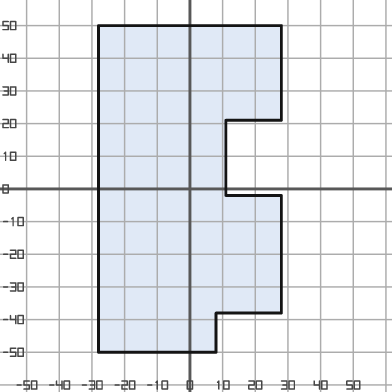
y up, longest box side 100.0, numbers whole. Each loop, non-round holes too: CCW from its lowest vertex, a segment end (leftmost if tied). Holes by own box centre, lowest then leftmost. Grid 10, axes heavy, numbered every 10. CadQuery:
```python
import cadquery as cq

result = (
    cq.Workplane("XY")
    .moveTo(-28.0, -50.0)
    .lineTo(8.0, -50.0)
    .lineTo(8.0, -38.0)
    .lineTo(28.0, -38.0)
    .lineTo(28.0, -2.0)
    .lineTo(11.0, -2.0)
    .lineTo(11.0, 21.0)
    .lineTo(28.0, 21.0)
    .lineTo(28.0, 50.0)
    .lineTo(-28.0, 50.0)
    .close()
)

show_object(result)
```